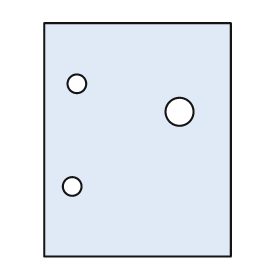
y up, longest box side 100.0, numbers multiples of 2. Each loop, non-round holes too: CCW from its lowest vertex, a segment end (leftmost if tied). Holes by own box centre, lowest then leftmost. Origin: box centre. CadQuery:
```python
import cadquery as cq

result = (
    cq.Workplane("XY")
    .moveTo(-40.0, -50.0)
    .lineTo(40.0, -50.0)
    .lineTo(40.0, 50.0)
    .lineTo(-40.0, 50.0)
    .close()
    .moveTo(-28.0, -20.0)
    .circle(4.0)
    .moveTo(18.0, 12.0)
    .circle(6.0)
    .moveTo(-26.0, 24.0)
    .circle(4.0)
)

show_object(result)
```